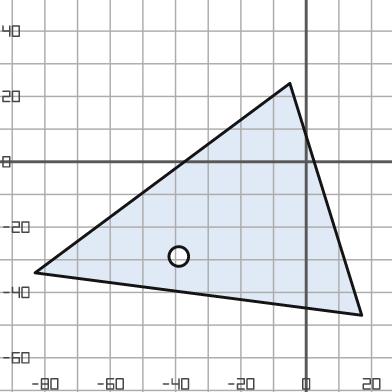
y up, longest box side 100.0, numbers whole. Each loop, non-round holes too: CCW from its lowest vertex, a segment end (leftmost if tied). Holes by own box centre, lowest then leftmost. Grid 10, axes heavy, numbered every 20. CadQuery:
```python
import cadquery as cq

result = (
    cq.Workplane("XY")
    .moveTo(17.0, -47.0)
    .lineTo(-5.0, 24.0)
    .lineTo(-83.0, -34.0)
    .close()
    .moveTo(-39.0, -29.0)
    .circle(3.0)
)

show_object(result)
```